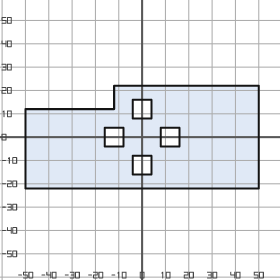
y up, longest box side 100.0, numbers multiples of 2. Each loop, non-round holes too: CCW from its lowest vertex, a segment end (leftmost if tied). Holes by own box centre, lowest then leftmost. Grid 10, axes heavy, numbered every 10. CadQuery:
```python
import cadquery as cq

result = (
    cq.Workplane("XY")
    .moveTo(-50.0, -22.0)
    .lineTo(50.0, -22.0)
    .lineTo(50.0, 22.0)
    .lineTo(-12.0, 22.0)
    .lineTo(-12.0, 12.0)
    .lineTo(-50.0, 12.0)
    .close()
    .moveTo(-4.0, -16.0)
    .lineTo(4.0, -16.0)
    .lineTo(4.0, -8.0)
    .lineTo(-4.0, -8.0)
    .close()
    .moveTo(-16.0, -4.0)
    .lineTo(-8.0, -4.0)
    .lineTo(-8.0, 4.0)
    .lineTo(-16.0, 4.0)
    .close()
    .moveTo(8.0, -4.0)
    .lineTo(16.0, -4.0)
    .lineTo(16.0, 4.0)
    .lineTo(8.0, 4.0)
    .close()
    .moveTo(-4.0, 8.0)
    .lineTo(4.0, 8.0)
    .lineTo(4.0, 16.0)
    .lineTo(-4.0, 16.0)
    .close()
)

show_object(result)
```